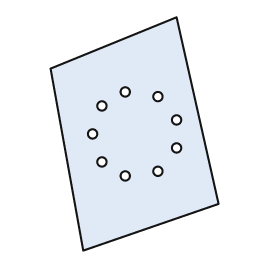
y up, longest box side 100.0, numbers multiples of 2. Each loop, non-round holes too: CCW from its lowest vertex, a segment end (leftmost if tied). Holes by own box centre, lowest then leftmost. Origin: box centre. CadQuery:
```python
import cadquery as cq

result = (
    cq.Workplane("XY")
    .moveTo(-22.0, -50.0)
    .lineTo(36.0, -30.0)
    .lineTo(18.0, 50.0)
    .lineTo(-36.0, 28.0)
    .close()
    .moveTo(-4.0, -18.0)
    .circle(2.0)
    .moveTo(10.0, -16.0)
    .circle(2.0)
    .moveTo(-14.0, -12.0)
    .circle(2.0)
    .moveTo(18.0, -6.0)
    .circle(2.0)
    .moveTo(-18.0, 0.0)
    .circle(2.0)
    .moveTo(18.0, 6.0)
    .circle(2.0)
    .moveTo(-14.0, 12.0)
    .circle(2.0)
    .moveTo(10.0, 16.0)
    .circle(2.0)
    .moveTo(-4.0, 18.0)
    .circle(2.0)
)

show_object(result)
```